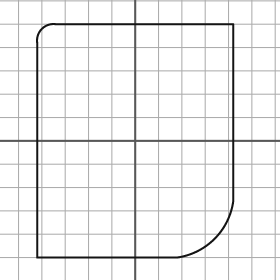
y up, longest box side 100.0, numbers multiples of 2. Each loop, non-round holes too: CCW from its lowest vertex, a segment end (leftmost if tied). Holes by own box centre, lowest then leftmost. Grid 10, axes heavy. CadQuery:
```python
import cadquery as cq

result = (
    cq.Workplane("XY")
    .moveTo(-42.0, -50.0)
    .lineTo(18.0, -50.0)
    .threePointArc((34.0, -42.0), (42.0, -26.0))
    .lineTo(42.0, 50.0)
    .lineTo(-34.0, 50.0)
    .threePointArc((-40.0, 48.0), (-42.0, 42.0))
    .close()
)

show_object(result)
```